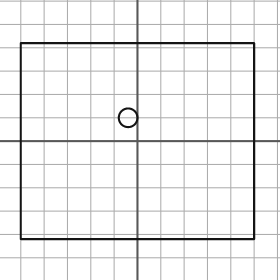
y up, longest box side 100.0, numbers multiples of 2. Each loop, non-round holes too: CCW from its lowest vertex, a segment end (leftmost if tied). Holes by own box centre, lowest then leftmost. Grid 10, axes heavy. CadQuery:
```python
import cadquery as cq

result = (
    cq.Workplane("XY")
    .moveTo(-50.0, -42.0)
    .lineTo(50.0, -42.0)
    .lineTo(50.0, 42.0)
    .lineTo(-50.0, 42.0)
    .close()
    .moveTo(-4.0, 10.0)
    .circle(4.0)
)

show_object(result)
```